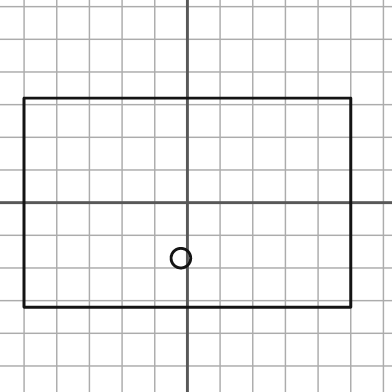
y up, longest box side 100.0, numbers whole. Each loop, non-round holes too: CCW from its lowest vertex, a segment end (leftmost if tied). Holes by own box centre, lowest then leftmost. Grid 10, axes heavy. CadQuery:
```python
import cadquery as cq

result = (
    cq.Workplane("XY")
    .moveTo(-50.0, -32.0)
    .lineTo(50.0, -32.0)
    .lineTo(50.0, 32.0)
    .lineTo(-50.0, 32.0)
    .close()
    .moveTo(-2.0, -17.0)
    .circle(3.0)
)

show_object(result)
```